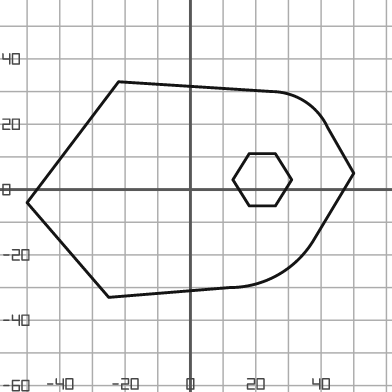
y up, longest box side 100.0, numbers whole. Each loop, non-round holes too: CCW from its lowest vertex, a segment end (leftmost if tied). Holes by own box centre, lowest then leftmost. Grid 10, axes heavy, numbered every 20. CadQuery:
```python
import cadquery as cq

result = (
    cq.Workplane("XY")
    .moveTo(-25.0, -33.0)
    .lineTo(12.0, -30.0)
    .threePointArc((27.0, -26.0), (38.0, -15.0))
    .lineTo(50.0, 5.0)
    .lineTo(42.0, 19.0)
    .threePointArc((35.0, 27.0), (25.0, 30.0))
    .lineTo(-22.0, 33.0)
    .lineTo(-50.0, -4.0)
    .close()
    .moveTo(18.0, -5.0)
    .lineTo(26.0, -5.0)
    .lineTo(31.0, 3.0)
    .lineTo(26.0, 11.0)
    .lineTo(18.0, 11.0)
    .lineTo(13.0, 3.0)
    .close()
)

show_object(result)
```